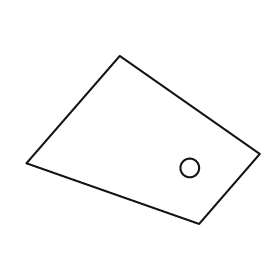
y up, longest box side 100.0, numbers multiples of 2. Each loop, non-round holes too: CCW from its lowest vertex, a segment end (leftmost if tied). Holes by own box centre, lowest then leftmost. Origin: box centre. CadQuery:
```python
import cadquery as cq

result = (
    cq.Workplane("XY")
    .moveTo(24.0, -36.0)
    .lineTo(50.0, -6.0)
    .lineTo(-10.0, 36.0)
    .lineTo(-50.0, -10.0)
    .close()
    .moveTo(20.0, -12.0)
    .circle(4.0)
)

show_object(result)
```